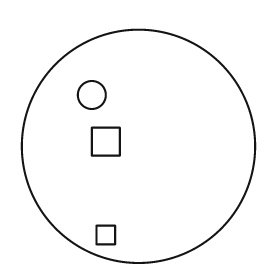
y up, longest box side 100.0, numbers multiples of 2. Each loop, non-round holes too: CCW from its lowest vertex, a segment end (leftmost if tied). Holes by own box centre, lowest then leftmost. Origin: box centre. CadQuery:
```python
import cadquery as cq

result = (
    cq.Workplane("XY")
    .moveTo(0.0, 0.0)
    .circle(50.0)
    .moveTo(-18.0, -42.0)
    .lineTo(-10.0, -42.0)
    .lineTo(-10.0, -34.0)
    .lineTo(-18.0, -34.0)
    .close()
    .moveTo(-20.0, -4.0)
    .lineTo(-8.0, -4.0)
    .lineTo(-8.0, 8.0)
    .lineTo(-20.0, 8.0)
    .close()
    .moveTo(-20.0, 22.0)
    .circle(6.0)
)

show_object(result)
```